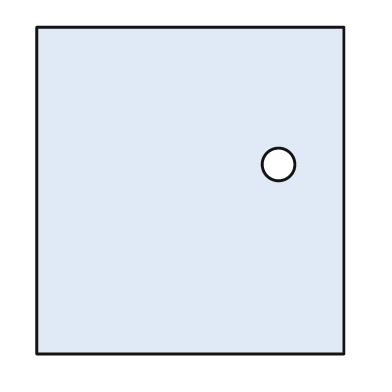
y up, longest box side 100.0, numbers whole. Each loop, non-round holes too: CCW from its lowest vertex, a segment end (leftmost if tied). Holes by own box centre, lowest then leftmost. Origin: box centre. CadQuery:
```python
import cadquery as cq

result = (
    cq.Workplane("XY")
    .moveTo(-47.0, -50.0)
    .lineTo(47.0, -50.0)
    .lineTo(47.0, 50.0)
    .lineTo(-47.0, 50.0)
    .close()
    .moveTo(27.0, 8.0)
    .circle(5.0)
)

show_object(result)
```